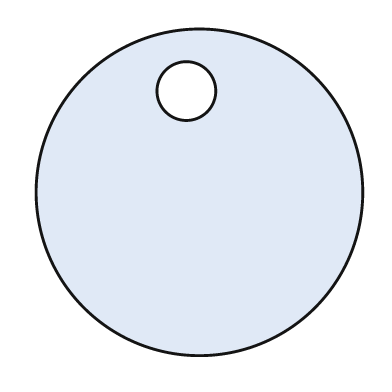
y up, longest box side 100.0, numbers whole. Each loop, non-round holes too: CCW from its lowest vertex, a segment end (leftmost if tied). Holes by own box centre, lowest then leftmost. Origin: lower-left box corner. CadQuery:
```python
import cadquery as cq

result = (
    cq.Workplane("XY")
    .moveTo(50.0, 50.0)
    .circle(50.0)
    .moveTo(46.0, 81.0)
    .circle(9.0)
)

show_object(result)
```